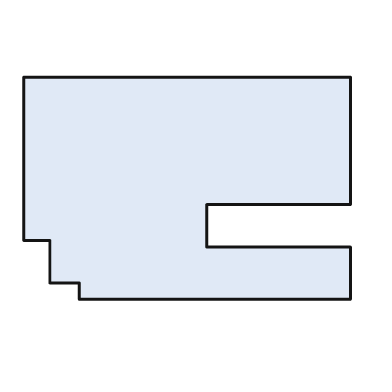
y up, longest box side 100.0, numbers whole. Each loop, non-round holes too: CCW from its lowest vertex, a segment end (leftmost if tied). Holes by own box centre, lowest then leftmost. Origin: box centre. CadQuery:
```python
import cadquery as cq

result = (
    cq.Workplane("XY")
    .moveTo(-33.0, -34.0)
    .lineTo(50.0, -34.0)
    .lineTo(50.0, -18.0)
    .lineTo(6.0, -18.0)
    .lineTo(6.0, -5.0)
    .lineTo(50.0, -5.0)
    .lineTo(50.0, 34.0)
    .lineTo(-50.0, 34.0)
    .lineTo(-50.0, -16.0)
    .lineTo(-42.0, -16.0)
    .lineTo(-42.0, -29.0)
    .lineTo(-33.0, -29.0)
    .close()
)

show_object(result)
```